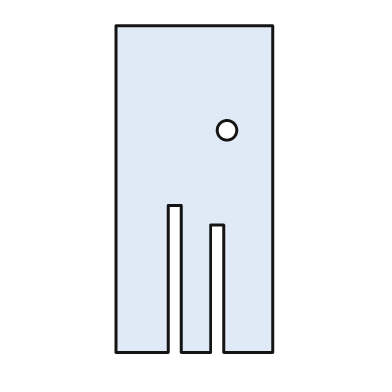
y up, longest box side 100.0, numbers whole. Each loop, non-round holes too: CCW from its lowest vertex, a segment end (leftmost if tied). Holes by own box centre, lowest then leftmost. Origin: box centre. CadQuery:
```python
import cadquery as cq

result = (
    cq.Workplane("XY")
    .moveTo(-24.0, -50.0)
    .lineTo(-8.0, -50.0)
    .lineTo(-8.0, -5.0)
    .lineTo(-4.0, -5.0)
    .lineTo(-4.0, -50.0)
    .lineTo(5.0, -50.0)
    .lineTo(5.0, -11.0)
    .lineTo(9.0, -11.0)
    .lineTo(9.0, -50.0)
    .lineTo(24.0, -50.0)
    .lineTo(24.0, 50.0)
    .lineTo(-24.0, 50.0)
    .close()
    .moveTo(10.0, 18.0)
    .circle(3.0)
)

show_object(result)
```